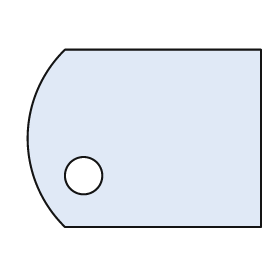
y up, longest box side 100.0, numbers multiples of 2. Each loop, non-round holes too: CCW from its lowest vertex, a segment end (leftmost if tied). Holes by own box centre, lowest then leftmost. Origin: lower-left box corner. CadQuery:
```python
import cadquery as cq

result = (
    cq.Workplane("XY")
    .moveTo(16.0, 0.0)
    .lineTo(100.0, 0.0)
    .lineTo(100.0, 76.0)
    .lineTo(16.0, 76.0)
    .threePointArc((0.0, 38.0), (16.0, 0.0))
    .close()
    .moveTo(24.0, 22.0)
    .circle(8.0)
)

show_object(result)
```